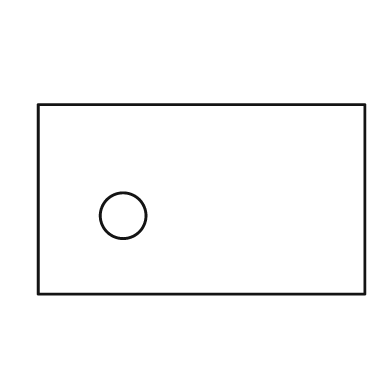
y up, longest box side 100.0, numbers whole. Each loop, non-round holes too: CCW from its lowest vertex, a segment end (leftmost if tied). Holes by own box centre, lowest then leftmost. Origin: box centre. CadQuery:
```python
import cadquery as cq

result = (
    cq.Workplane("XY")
    .moveTo(-50.0, -29.0)
    .lineTo(50.0, -29.0)
    .lineTo(50.0, 29.0)
    .lineTo(-50.0, 29.0)
    .close()
    .moveTo(-24.0, -5.0)
    .circle(7.0)
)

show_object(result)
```